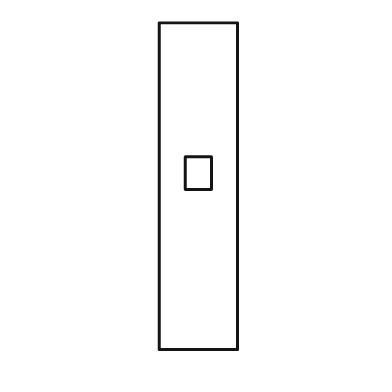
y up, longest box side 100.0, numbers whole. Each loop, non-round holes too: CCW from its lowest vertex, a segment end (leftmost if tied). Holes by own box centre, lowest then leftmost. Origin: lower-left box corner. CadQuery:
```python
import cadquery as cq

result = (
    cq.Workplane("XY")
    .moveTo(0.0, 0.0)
    .lineTo(24.0, 0.0)
    .lineTo(24.0, 100.0)
    .lineTo(0.0, 100.0)
    .close()
    .moveTo(8.0, 49.0)
    .lineTo(16.0, 49.0)
    .lineTo(16.0, 59.0)
    .lineTo(8.0, 59.0)
    .close()
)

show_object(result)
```